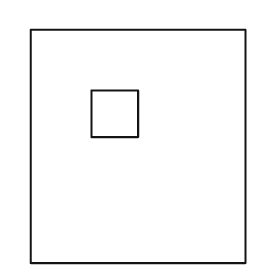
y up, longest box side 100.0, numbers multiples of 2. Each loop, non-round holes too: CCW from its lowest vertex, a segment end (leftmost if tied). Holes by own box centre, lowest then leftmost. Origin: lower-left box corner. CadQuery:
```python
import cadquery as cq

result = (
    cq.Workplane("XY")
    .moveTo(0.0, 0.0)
    .lineTo(92.0, 0.0)
    .lineTo(92.0, 100.0)
    .lineTo(0.0, 100.0)
    .close()
    .moveTo(26.0, 54.0)
    .lineTo(46.0, 54.0)
    .lineTo(46.0, 74.0)
    .lineTo(26.0, 74.0)
    .close()
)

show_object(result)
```